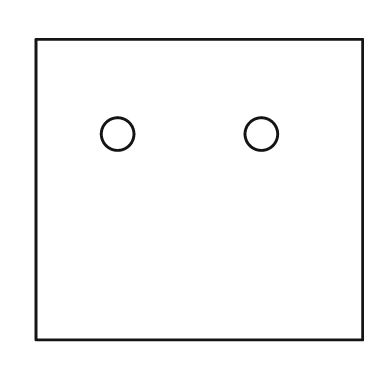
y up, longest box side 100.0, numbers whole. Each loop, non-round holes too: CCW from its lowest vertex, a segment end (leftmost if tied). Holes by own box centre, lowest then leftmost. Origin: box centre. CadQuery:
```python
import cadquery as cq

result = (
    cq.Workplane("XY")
    .moveTo(-50.0, -46.0)
    .lineTo(50.0, -46.0)
    .lineTo(50.0, 46.0)
    .lineTo(-50.0, 46.0)
    .close()
    .moveTo(-25.0, 17.0)
    .circle(5.0)
    .moveTo(19.0, 17.0)
    .circle(5.0)
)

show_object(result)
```